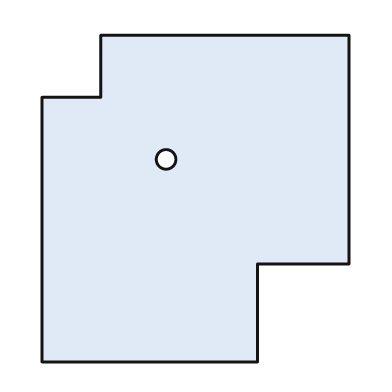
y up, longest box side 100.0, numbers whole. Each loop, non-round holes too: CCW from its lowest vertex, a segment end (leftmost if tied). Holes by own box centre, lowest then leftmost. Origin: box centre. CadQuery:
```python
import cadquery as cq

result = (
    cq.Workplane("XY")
    .moveTo(-47.0, -50.0)
    .lineTo(19.0, -50.0)
    .lineTo(19.0, -20.0)
    .lineTo(47.0, -20.0)
    .lineTo(47.0, 50.0)
    .lineTo(-29.0, 50.0)
    .lineTo(-29.0, 31.0)
    .lineTo(-47.0, 31.0)
    .close()
    .moveTo(-9.0, 12.0)
    .circle(3.0)
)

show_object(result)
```